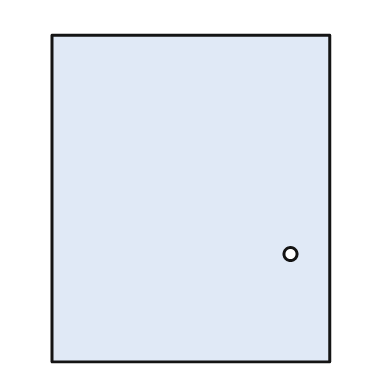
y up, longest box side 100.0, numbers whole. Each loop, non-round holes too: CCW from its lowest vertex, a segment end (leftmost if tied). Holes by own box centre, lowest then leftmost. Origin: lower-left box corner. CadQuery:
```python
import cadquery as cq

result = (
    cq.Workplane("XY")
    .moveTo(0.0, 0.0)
    .lineTo(85.0, 0.0)
    .lineTo(85.0, 100.0)
    .lineTo(0.0, 100.0)
    .close()
    .moveTo(73.0, 33.0)
    .circle(2.0)
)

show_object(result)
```